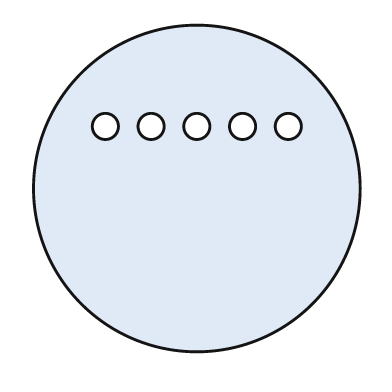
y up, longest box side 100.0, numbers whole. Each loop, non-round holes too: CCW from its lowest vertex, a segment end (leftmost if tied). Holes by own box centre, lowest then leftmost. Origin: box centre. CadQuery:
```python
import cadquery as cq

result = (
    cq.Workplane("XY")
    .moveTo(0.0, 0.0)
    .circle(50.0)
    .moveTo(-28.0, 19.0)
    .circle(4.0)
    .moveTo(-14.0, 19.0)
    .circle(4.0)
    .moveTo(0.0, 19.0)
    .circle(4.0)
    .moveTo(14.0, 19.0)
    .circle(4.0)
    .moveTo(28.0, 19.0)
    .circle(4.0)
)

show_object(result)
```